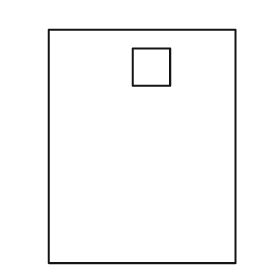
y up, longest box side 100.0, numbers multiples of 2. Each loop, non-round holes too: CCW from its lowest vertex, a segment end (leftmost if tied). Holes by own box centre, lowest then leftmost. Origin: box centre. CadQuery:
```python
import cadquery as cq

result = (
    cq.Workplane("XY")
    .moveTo(-40.0, -50.0)
    .lineTo(40.0, -50.0)
    .lineTo(40.0, 50.0)
    .lineTo(-40.0, 50.0)
    .close()
    .moveTo(-4.0, 26.0)
    .lineTo(12.0, 26.0)
    .lineTo(12.0, 42.0)
    .lineTo(-4.0, 42.0)
    .close()
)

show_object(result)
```